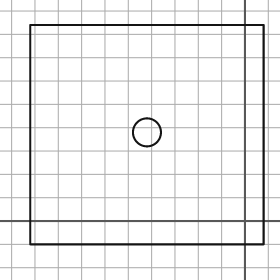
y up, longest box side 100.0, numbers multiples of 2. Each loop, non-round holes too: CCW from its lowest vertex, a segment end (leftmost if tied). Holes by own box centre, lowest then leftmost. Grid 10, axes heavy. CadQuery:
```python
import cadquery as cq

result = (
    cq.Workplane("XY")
    .moveTo(-92.0, -10.0)
    .lineTo(8.0, -10.0)
    .lineTo(8.0, 84.0)
    .lineTo(-92.0, 84.0)
    .close()
    .moveTo(-42.0, 38.0)
    .circle(6.0)
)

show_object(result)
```